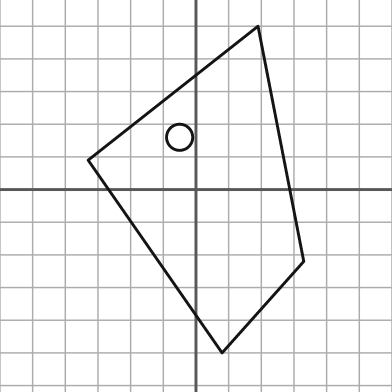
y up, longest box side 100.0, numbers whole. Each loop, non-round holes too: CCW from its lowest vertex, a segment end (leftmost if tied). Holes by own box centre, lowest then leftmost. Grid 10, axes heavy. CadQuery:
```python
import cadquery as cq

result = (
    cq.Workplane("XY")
    .moveTo(8.0, -50.0)
    .lineTo(33.0, -22.0)
    .lineTo(19.0, 50.0)
    .lineTo(-33.0, 9.0)
    .close()
    .moveTo(-5.0, 16.0)
    .circle(4.0)
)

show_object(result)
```